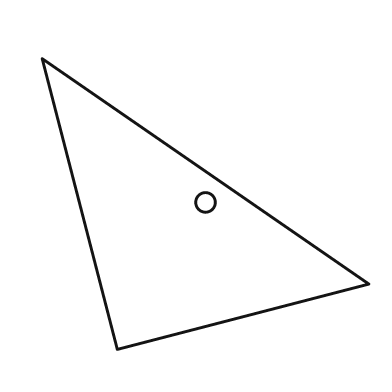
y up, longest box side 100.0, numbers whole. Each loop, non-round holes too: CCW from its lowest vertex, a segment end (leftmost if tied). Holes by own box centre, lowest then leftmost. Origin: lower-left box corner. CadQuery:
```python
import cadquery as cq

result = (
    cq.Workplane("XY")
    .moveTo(23.0, 0.0)
    .lineTo(100.0, 20.0)
    .lineTo(0.0, 89.0)
    .close()
    .moveTo(50.0, 45.0)
    .circle(3.0)
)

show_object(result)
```